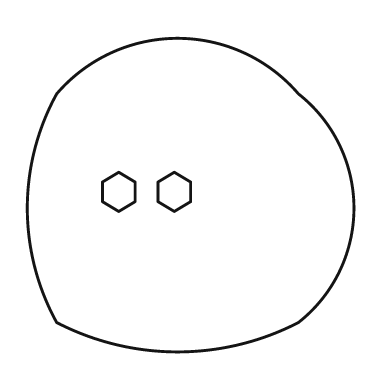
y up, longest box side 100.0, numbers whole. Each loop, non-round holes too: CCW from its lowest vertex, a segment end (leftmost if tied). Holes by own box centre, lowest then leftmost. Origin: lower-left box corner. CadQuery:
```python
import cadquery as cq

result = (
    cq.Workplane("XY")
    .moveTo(9.0, 9.0)
    .threePointArc((46.0, 0.0), (83.0, 9.0))
    .threePointArc((100.0, 44.0), (83.0, 79.0))
    .threePointArc((46.0, 96.0), (9.0, 79.0))
    .threePointArc((0.0, 44.0), (9.0, 9.0))
    .close()
    .moveTo(28.0, 43.0)
    .lineTo(33.0, 46.0)
    .lineTo(33.0, 52.0)
    .lineTo(28.0, 55.0)
    .lineTo(23.0, 52.0)
    .lineTo(23.0, 46.0)
    .close()
    .moveTo(45.0, 43.0)
    .lineTo(50.0, 46.0)
    .lineTo(50.0, 52.0)
    .lineTo(45.0, 55.0)
    .lineTo(40.0, 52.0)
    .lineTo(40.0, 46.0)
    .close()
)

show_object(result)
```